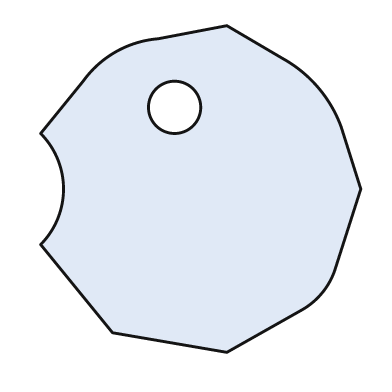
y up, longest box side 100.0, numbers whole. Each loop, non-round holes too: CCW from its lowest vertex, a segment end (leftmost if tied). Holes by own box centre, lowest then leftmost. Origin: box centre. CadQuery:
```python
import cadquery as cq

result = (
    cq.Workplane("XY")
    .moveTo(8.0, -50.0)
    .lineTo(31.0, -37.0)
    .threePointArc((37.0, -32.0), (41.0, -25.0))
    .lineTo(49.0, 0.0)
    .lineTo(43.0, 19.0)
    .threePointArc((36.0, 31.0), (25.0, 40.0))
    .lineTo(8.0, 50.0)
    .lineTo(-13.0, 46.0)
    .threePointArc((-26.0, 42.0), (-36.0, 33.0))
    .lineTo(-49.0, 17.0)
    .threePointArc((-42.0, 0.0), (-49.0, -17.0))
    .lineTo(-27.0, -44.0)
    .close()
    .moveTo(-8.0, 25.0)
    .circle(8.0)
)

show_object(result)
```